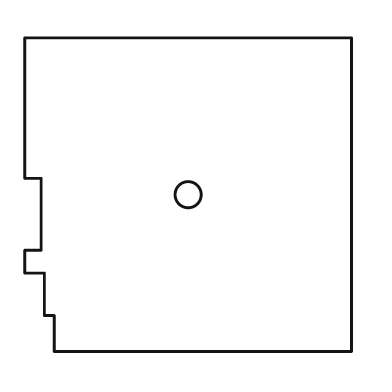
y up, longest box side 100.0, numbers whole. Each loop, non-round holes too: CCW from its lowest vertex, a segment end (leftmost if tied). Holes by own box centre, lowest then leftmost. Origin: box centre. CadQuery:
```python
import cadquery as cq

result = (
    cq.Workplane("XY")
    .moveTo(-41.0, -48.0)
    .lineTo(50.0, -48.0)
    .lineTo(50.0, 48.0)
    .lineTo(-50.0, 48.0)
    .lineTo(-50.0, 5.0)
    .lineTo(-45.0, 5.0)
    .lineTo(-45.0, -17.0)
    .lineTo(-50.0, -17.0)
    .lineTo(-50.0, -24.0)
    .lineTo(-44.0, -24.0)
    .lineTo(-44.0, -37.0)
    .lineTo(-41.0, -37.0)
    .close()
    .moveTo(0.0, 0.0)
    .circle(4.0)
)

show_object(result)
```